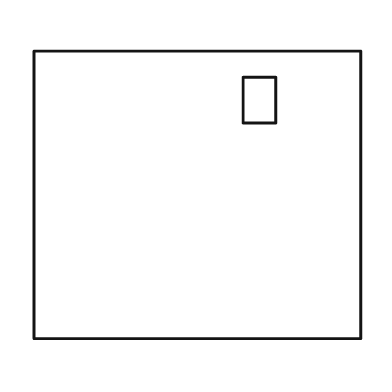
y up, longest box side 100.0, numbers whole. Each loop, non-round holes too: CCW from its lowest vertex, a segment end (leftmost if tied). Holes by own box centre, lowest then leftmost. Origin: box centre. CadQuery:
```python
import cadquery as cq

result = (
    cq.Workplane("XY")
    .moveTo(-50.0, -44.0)
    .lineTo(50.0, -44.0)
    .lineTo(50.0, 44.0)
    .lineTo(-50.0, 44.0)
    .close()
    .moveTo(14.0, 22.0)
    .lineTo(24.0, 22.0)
    .lineTo(24.0, 36.0)
    .lineTo(14.0, 36.0)
    .close()
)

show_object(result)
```